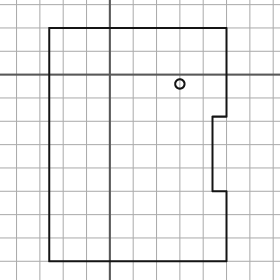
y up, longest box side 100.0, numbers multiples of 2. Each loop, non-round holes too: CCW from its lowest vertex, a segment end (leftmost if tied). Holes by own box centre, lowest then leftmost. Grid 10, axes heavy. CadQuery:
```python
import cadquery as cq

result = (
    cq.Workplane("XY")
    .moveTo(-26.0, -80.0)
    .lineTo(50.0, -80.0)
    .lineTo(50.0, -50.0)
    .lineTo(44.0, -50.0)
    .lineTo(44.0, -18.0)
    .lineTo(50.0, -18.0)
    .lineTo(50.0, 20.0)
    .lineTo(-26.0, 20.0)
    .close()
    .moveTo(30.0, -4.0)
    .circle(2.0)
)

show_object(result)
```